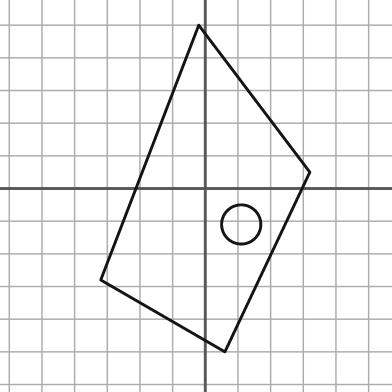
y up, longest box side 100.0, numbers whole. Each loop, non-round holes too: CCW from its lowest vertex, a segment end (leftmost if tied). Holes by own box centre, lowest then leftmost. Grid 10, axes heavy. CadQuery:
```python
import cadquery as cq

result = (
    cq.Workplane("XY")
    .moveTo(6.0, -50.0)
    .lineTo(32.0, 5.0)
    .lineTo(-2.0, 50.0)
    .lineTo(-32.0, -28.0)
    .close()
    .moveTo(11.0, -11.0)
    .circle(6.0)
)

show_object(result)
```